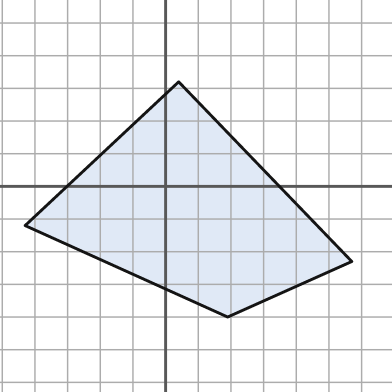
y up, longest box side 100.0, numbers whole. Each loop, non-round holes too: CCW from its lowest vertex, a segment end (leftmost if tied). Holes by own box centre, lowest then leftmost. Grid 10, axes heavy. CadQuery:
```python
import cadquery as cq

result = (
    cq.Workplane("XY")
    .moveTo(19.0, -40.0)
    .lineTo(57.0, -23.0)
    .lineTo(4.0, 32.0)
    .lineTo(-43.0, -12.0)
    .close()
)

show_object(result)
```